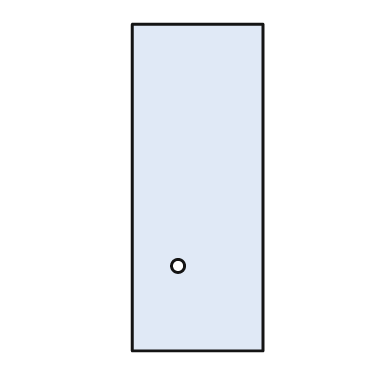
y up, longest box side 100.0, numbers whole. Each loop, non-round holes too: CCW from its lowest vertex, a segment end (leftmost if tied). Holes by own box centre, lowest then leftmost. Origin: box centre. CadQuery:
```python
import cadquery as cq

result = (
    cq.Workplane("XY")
    .moveTo(-20.0, -50.0)
    .lineTo(20.0, -50.0)
    .lineTo(20.0, 50.0)
    .lineTo(-20.0, 50.0)
    .close()
    .moveTo(-6.0, -24.0)
    .circle(2.0)
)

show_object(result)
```